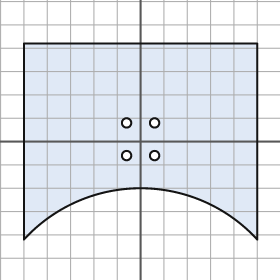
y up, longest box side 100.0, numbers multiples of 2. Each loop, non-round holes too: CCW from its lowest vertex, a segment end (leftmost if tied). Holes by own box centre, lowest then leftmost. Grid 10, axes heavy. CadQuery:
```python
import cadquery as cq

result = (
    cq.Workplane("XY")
    .moveTo(-50.0, -42.0)
    .threePointArc((0.0, -20.0), (50.0, -42.0))
    .lineTo(50.0, 42.0)
    .lineTo(-50.0, 42.0)
    .close()
    .moveTo(-6.0, -6.0)
    .circle(2.0)
    .moveTo(6.0, -6.0)
    .circle(2.0)
    .moveTo(-6.0, 8.0)
    .circle(2.0)
    .moveTo(6.0, 8.0)
    .circle(2.0)
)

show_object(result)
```